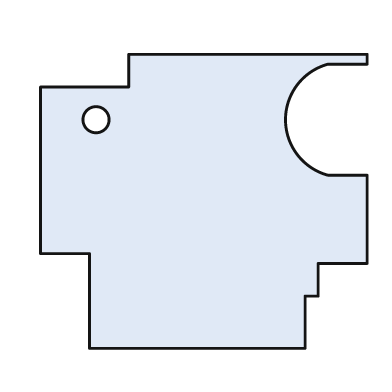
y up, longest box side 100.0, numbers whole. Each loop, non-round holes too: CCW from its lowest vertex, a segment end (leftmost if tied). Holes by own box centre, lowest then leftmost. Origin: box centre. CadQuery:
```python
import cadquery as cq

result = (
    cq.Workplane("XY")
    .moveTo(-35.0, -45.0)
    .lineTo(31.0, -45.0)
    .lineTo(31.0, -29.0)
    .lineTo(35.0, -29.0)
    .lineTo(35.0, -19.0)
    .lineTo(50.0, -19.0)
    .lineTo(50.0, 8.0)
    .lineTo(38.0, 8.0)
    .threePointArc((25.0, 25.0), (38.0, 42.0))
    .lineTo(50.0, 42.0)
    .lineTo(50.0, 45.0)
    .lineTo(-23.0, 45.0)
    .lineTo(-23.0, 35.0)
    .lineTo(-50.0, 35.0)
    .lineTo(-50.0, -16.0)
    .lineTo(-35.0, -16.0)
    .close()
    .moveTo(-33.0, 25.0)
    .circle(4.0)
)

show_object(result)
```